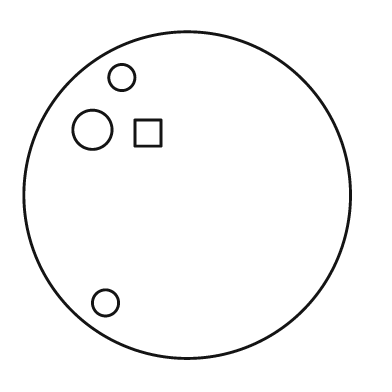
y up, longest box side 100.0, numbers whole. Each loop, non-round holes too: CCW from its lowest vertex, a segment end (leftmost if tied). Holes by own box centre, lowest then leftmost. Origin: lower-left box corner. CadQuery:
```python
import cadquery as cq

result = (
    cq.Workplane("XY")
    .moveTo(50.0, 50.0)
    .circle(50.0)
    .moveTo(25.0, 17.0)
    .circle(4.0)
    .moveTo(34.0, 65.0)
    .lineTo(42.0, 65.0)
    .lineTo(42.0, 73.0)
    .lineTo(34.0, 73.0)
    .close()
    .moveTo(21.0, 70.0)
    .circle(6.0)
    .moveTo(30.0, 86.0)
    .circle(4.0)
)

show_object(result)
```